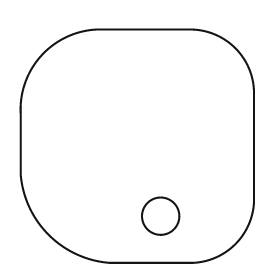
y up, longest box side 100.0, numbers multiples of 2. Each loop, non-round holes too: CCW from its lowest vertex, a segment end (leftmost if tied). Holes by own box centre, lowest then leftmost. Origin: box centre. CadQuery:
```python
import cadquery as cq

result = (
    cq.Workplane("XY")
    .moveTo(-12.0, -50.0)
    .lineTo(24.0, -50.0)
    .threePointArc((42.0, -42.0), (50.0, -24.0))
    .lineTo(50.0, 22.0)
    .threePointArc((42.0, 42.0), (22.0, 50.0))
    .lineTo(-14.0, 50.0)
    .threePointArc((-40.0, 40.0), (-50.0, 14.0))
    .lineTo(-50.0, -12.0)
    .threePointArc((-38.0, -38.0), (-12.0, -50.0))
    .close()
    .moveTo(10.0, -30.0)
    .circle(8.0)
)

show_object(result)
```